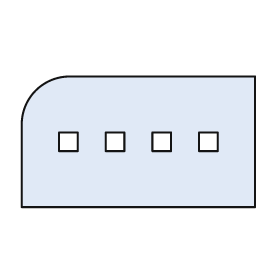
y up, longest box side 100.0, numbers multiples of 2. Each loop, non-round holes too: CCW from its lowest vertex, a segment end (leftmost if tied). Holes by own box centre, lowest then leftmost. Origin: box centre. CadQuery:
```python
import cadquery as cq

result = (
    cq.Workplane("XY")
    .moveTo(-50.0, -28.0)
    .lineTo(50.0, -28.0)
    .lineTo(50.0, 28.0)
    .lineTo(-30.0, 28.0)
    .threePointArc((-44.0, 22.0), (-50.0, 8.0))
    .close()
    .moveTo(-34.0, -4.0)
    .lineTo(-26.0, -4.0)
    .lineTo(-26.0, 4.0)
    .lineTo(-34.0, 4.0)
    .close()
    .moveTo(-14.0, -4.0)
    .lineTo(-6.0, -4.0)
    .lineTo(-6.0, 4.0)
    .lineTo(-14.0, 4.0)
    .close()
    .moveTo(6.0, -4.0)
    .lineTo(14.0, -4.0)
    .lineTo(14.0, 4.0)
    .lineTo(6.0, 4.0)
    .close()
    .moveTo(26.0, -4.0)
    .lineTo(34.0, -4.0)
    .lineTo(34.0, 4.0)
    .lineTo(26.0, 4.0)
    .close()
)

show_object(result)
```